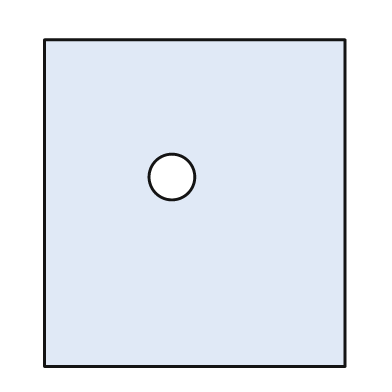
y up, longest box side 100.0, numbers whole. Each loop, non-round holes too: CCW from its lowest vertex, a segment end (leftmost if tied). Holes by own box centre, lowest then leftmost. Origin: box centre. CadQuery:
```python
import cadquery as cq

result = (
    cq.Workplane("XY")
    .moveTo(-46.0, -50.0)
    .lineTo(46.0, -50.0)
    .lineTo(46.0, 50.0)
    .lineTo(-46.0, 50.0)
    .close()
    .moveTo(-7.0, 8.0)
    .circle(7.0)
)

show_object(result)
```